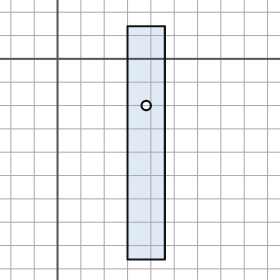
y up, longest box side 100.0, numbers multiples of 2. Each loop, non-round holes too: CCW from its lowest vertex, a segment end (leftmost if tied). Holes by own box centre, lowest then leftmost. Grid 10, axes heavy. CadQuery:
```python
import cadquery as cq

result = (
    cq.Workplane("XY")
    .moveTo(30.0, -86.0)
    .lineTo(46.0, -86.0)
    .lineTo(46.0, 14.0)
    .lineTo(30.0, 14.0)
    .close()
    .moveTo(38.0, -20.0)
    .circle(2.0)
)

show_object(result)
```